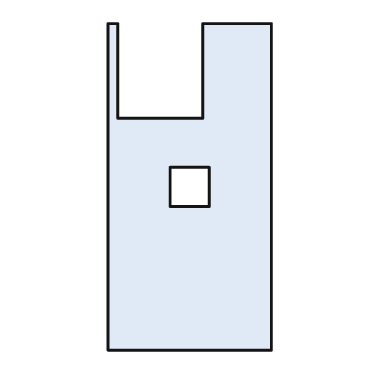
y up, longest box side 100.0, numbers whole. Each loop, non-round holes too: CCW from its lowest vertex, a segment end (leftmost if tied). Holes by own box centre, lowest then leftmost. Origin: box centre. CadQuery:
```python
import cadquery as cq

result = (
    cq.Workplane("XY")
    .moveTo(-25.0, -50.0)
    .lineTo(25.0, -50.0)
    .lineTo(25.0, 50.0)
    .lineTo(4.0, 50.0)
    .lineTo(4.0, 21.0)
    .lineTo(-22.0, 21.0)
    .lineTo(-22.0, 50.0)
    .lineTo(-25.0, 50.0)
    .close()
    .moveTo(-6.0, -6.0)
    .lineTo(6.0, -6.0)
    .lineTo(6.0, 6.0)
    .lineTo(-6.0, 6.0)
    .close()
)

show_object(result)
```